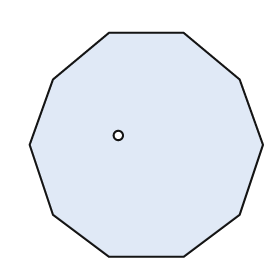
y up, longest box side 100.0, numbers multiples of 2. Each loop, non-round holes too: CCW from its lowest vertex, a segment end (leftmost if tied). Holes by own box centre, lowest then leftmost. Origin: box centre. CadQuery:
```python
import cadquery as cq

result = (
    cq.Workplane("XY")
    .moveTo(-16.0, -48.0)
    .lineTo(16.0, -48.0)
    .lineTo(40.0, -30.0)
    .lineTo(50.0, 0.0)
    .lineTo(40.0, 28.0)
    .lineTo(16.0, 48.0)
    .lineTo(-16.0, 48.0)
    .lineTo(-40.0, 28.0)
    .lineTo(-50.0, 0.0)
    .lineTo(-40.0, -30.0)
    .close()
    .moveTo(-12.0, 4.0)
    .circle(2.0)
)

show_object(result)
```